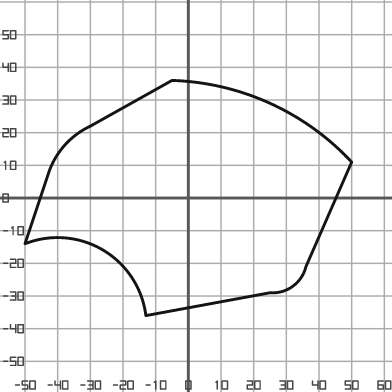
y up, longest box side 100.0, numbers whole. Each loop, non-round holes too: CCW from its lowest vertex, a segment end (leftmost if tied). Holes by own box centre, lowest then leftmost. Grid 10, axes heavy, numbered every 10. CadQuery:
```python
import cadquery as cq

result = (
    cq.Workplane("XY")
    .moveTo(-13.0, -36.0)
    .lineTo(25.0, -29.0)
    .threePointArc((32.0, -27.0), (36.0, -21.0))
    .lineTo(50.0, 11.0)
    .threePointArc((25.0, 29.0), (-5.0, 36.0))
    .lineTo(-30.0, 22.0)
    .threePointArc((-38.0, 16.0), (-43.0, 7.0))
    .lineTo(-50.0, -14.0)
    .threePointArc((-26.0, -16.0), (-13.0, -36.0))
    .close()
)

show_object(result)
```